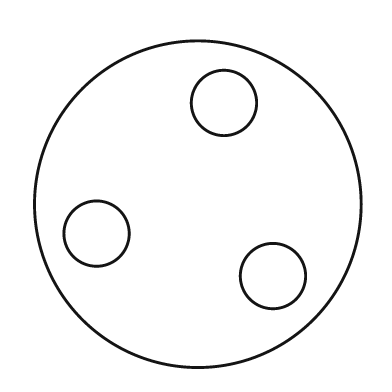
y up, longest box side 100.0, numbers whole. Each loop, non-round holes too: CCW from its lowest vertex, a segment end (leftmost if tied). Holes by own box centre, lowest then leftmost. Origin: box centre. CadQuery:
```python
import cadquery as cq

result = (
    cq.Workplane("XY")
    .moveTo(0.0, 0.0)
    .circle(50.0)
    .moveTo(23.0, -22.0)
    .circle(10.0)
    .moveTo(-31.0, -9.0)
    .circle(10.0)
    .moveTo(8.0, 31.0)
    .circle(10.0)
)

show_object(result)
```